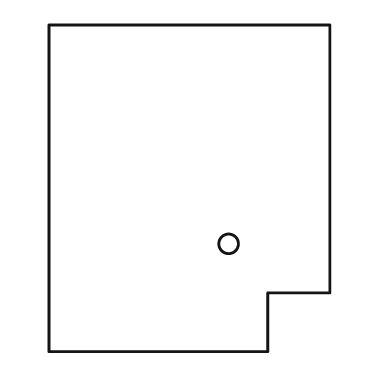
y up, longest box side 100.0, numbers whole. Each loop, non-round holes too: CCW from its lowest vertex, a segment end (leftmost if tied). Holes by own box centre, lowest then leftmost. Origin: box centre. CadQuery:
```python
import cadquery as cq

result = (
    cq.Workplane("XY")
    .moveTo(-43.0, -50.0)
    .lineTo(24.0, -50.0)
    .lineTo(24.0, -32.0)
    .lineTo(43.0, -32.0)
    .lineTo(43.0, 50.0)
    .lineTo(-43.0, 50.0)
    .close()
    .moveTo(12.0, -17.0)
    .circle(3.0)
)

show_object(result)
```